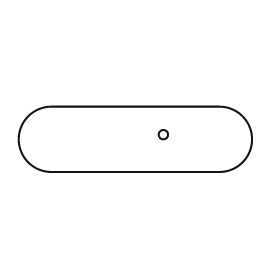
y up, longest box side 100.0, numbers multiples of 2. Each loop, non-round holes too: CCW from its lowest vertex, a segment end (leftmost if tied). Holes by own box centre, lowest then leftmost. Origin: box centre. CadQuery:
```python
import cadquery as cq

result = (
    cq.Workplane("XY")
    .moveTo(-36.0, -14.0)
    .lineTo(36.0, -14.0)
    .threePointArc((50.0, 0.0), (36.0, 14.0))
    .lineTo(-36.0, 14.0)
    .threePointArc((-50.0, 0.0), (-36.0, -14.0))
    .close()
    .moveTo(12.0, 2.0)
    .circle(2.0)
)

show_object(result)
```